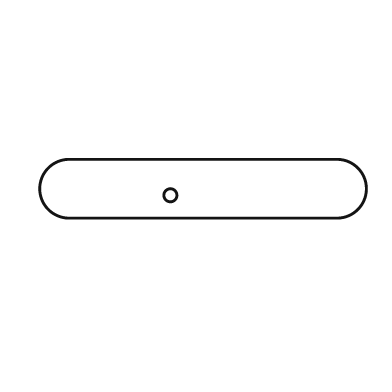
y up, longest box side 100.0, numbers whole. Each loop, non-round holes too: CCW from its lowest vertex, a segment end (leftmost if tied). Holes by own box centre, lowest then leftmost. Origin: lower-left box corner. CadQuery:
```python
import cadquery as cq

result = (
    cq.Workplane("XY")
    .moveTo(9.0, 0.0)
    .lineTo(91.0, 0.0)
    .threePointArc((100.0, 9.0), (91.0, 18.0))
    .lineTo(9.0, 18.0)
    .threePointArc((0.0, 9.0), (9.0, 0.0))
    .close()
    .moveTo(40.0, 7.0)
    .circle(2.0)
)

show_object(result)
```